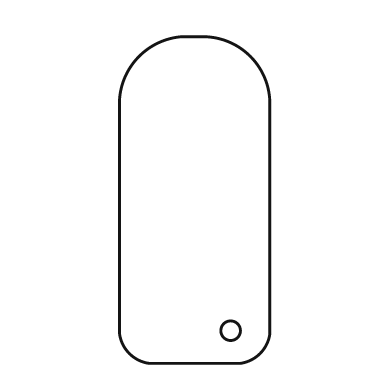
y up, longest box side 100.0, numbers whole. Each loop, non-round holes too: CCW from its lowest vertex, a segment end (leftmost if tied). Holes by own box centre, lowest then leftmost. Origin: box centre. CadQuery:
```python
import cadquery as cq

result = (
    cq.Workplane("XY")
    .moveTo(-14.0, -50.0)
    .lineTo(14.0, -50.0)
    .threePointArc((20.0, -47.0), (23.0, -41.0))
    .lineTo(23.0, 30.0)
    .threePointArc((17.0, 44.0), (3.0, 50.0))
    .lineTo(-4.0, 50.0)
    .threePointArc((-17.0, 44.0), (-23.0, 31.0))
    .lineTo(-23.0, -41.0)
    .threePointArc((-20.0, -47.0), (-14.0, -50.0))
    .close()
    .moveTo(11.0, -40.0)
    .circle(3.0)
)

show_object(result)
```